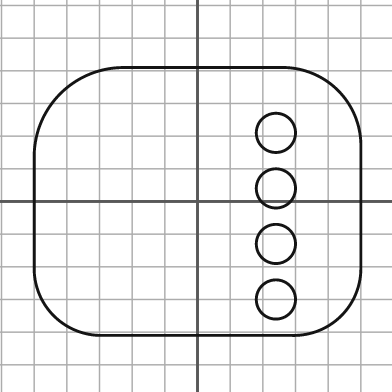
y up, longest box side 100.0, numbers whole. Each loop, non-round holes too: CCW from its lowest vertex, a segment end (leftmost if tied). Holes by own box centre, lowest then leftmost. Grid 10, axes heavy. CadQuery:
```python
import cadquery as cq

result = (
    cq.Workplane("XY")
    .moveTo(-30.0, -41.0)
    .lineTo(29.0, -41.0)
    .threePointArc((44.0, -35.0), (50.0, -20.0))
    .lineTo(50.0, 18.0)
    .threePointArc((43.0, 34.0), (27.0, 41.0))
    .lineTo(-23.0, 41.0)
    .threePointArc((-42.0, 33.0), (-50.0, 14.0))
    .lineTo(-50.0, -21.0)
    .threePointArc((-44.0, -35.0), (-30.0, -41.0))
    .close()
    .moveTo(24.0, -30.0)
    .circle(6.0)
    .moveTo(24.0, -13.0)
    .circle(6.0)
    .moveTo(24.0, 4.0)
    .circle(6.0)
    .moveTo(24.0, 21.0)
    .circle(6.0)
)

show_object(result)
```